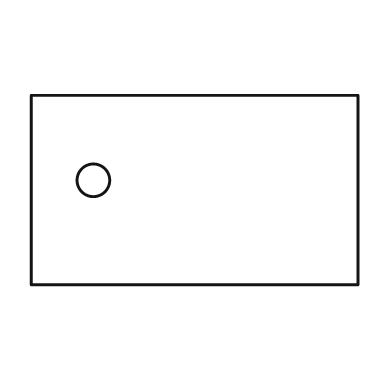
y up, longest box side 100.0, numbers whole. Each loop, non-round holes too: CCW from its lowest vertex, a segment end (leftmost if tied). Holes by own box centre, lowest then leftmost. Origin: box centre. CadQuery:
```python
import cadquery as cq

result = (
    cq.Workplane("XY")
    .moveTo(-50.0, -29.0)
    .lineTo(50.0, -29.0)
    .lineTo(50.0, 29.0)
    .lineTo(-50.0, 29.0)
    .close()
    .moveTo(-31.0, 3.0)
    .circle(5.0)
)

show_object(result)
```